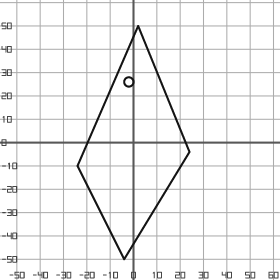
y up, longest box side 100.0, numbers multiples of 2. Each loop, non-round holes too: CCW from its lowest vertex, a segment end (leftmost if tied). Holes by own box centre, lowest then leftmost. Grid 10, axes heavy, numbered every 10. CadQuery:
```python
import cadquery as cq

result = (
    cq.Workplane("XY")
    .moveTo(-4.0, -50.0)
    .lineTo(24.0, -4.0)
    .lineTo(2.0, 50.0)
    .lineTo(-24.0, -10.0)
    .close()
    .moveTo(-2.0, 26.0)
    .circle(2.0)
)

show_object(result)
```